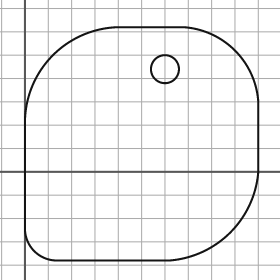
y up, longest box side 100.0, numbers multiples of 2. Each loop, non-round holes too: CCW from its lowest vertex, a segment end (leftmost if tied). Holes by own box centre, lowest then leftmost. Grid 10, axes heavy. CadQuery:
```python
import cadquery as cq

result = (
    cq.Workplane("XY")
    .moveTo(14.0, -38.0)
    .lineTo(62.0, -38.0)
    .threePointArc((88.0, -26.0), (100.0, 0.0))
    .lineTo(100.0, 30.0)
    .threePointArc((90.0, 52.0), (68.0, 62.0))
    .lineTo(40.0, 62.0)
    .threePointArc((12.0, 50.0), (0.0, 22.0))
    .lineTo(0.0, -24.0)
    .threePointArc((4.0, -34.0), (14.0, -38.0))
    .close()
    .moveTo(60.0, 44.0)
    .circle(6.0)
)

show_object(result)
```